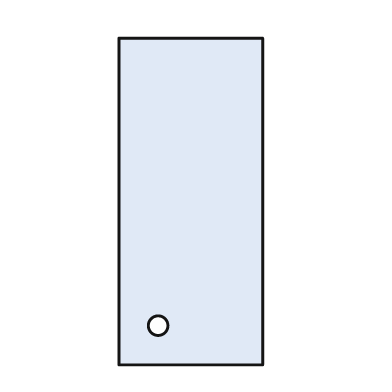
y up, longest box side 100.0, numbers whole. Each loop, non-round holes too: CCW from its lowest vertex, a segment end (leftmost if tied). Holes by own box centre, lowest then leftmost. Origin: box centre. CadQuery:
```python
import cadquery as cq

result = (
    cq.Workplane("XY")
    .moveTo(-22.0, -50.0)
    .lineTo(22.0, -50.0)
    .lineTo(22.0, 50.0)
    .lineTo(-22.0, 50.0)
    .close()
    .moveTo(-10.0, -38.0)
    .circle(3.0)
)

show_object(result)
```